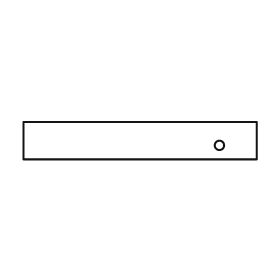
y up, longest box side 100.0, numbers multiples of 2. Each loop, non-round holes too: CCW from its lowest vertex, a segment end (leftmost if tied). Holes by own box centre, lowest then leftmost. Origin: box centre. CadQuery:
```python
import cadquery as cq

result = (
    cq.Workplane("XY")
    .moveTo(-50.0, -8.0)
    .lineTo(50.0, -8.0)
    .lineTo(50.0, 8.0)
    .lineTo(-50.0, 8.0)
    .close()
    .moveTo(34.0, -2.0)
    .circle(2.0)
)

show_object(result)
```